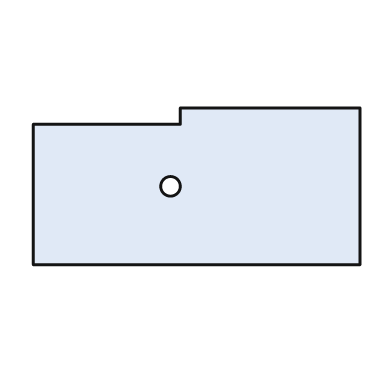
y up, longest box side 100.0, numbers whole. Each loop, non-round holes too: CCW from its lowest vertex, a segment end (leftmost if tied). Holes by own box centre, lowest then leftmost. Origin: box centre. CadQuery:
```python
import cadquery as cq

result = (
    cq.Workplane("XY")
    .moveTo(-50.0, -24.0)
    .lineTo(50.0, -24.0)
    .lineTo(50.0, 24.0)
    .lineTo(-5.0, 24.0)
    .lineTo(-5.0, 19.0)
    .lineTo(-50.0, 19.0)
    .close()
    .moveTo(-8.0, 0.0)
    .circle(3.0)
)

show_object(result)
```